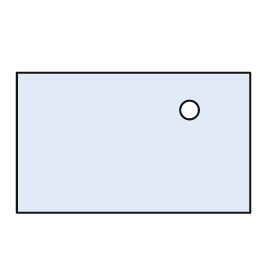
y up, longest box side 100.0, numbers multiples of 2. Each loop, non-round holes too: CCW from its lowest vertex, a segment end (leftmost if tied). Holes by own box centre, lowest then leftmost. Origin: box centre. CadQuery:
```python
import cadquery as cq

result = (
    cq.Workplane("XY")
    .moveTo(-50.0, -30.0)
    .lineTo(50.0, -30.0)
    .lineTo(50.0, 30.0)
    .lineTo(-50.0, 30.0)
    .close()
    .moveTo(24.0, 14.0)
    .circle(4.0)
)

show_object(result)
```